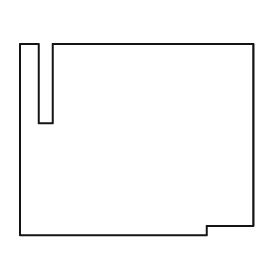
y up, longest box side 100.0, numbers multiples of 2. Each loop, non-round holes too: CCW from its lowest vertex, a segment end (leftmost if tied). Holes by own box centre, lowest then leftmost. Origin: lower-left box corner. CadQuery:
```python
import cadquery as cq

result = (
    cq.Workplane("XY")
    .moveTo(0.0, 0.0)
    .lineTo(80.0, 0.0)
    .lineTo(80.0, 4.0)
    .lineTo(100.0, 4.0)
    .lineTo(100.0, 82.0)
    .lineTo(14.0, 82.0)
    .lineTo(14.0, 48.0)
    .lineTo(8.0, 48.0)
    .lineTo(8.0, 82.0)
    .lineTo(0.0, 82.0)
    .close()
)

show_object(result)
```